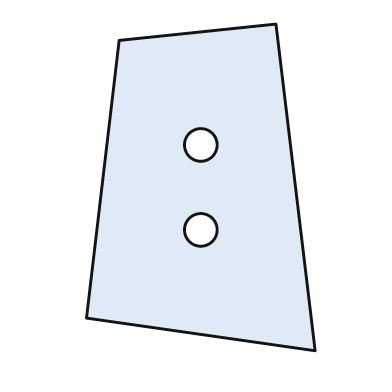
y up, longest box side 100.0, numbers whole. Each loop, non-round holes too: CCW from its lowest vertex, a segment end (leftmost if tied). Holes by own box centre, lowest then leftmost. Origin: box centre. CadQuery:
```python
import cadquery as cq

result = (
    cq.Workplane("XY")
    .moveTo(35.0, -50.0)
    .lineTo(23.0, 50.0)
    .lineTo(-25.0, 45.0)
    .lineTo(-35.0, -40.0)
    .close()
    .moveTo(0.0, -13.0)
    .circle(5.0)
    .moveTo(0.0, 13.0)
    .circle(5.0)
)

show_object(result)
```